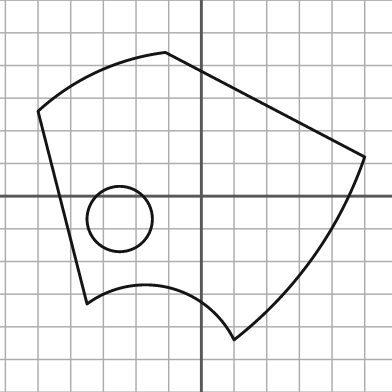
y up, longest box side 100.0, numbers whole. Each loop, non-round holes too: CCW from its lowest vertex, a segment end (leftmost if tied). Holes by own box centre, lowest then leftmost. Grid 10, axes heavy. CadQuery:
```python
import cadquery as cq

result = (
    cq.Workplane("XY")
    .moveTo(10.0, -44.0)
    .threePointArc((34.0, -19.0), (50.0, 12.0))
    .lineTo(-11.0, 44.0)
    .threePointArc((-32.0, 38.0), (-50.0, 26.0))
    .lineTo(-35.0, -33.0)
    .threePointArc((-10.0, -28.0), (10.0, -44.0))
    .close()
    .moveTo(-25.0, -7.0)
    .circle(10.0)
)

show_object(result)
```